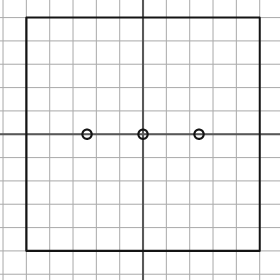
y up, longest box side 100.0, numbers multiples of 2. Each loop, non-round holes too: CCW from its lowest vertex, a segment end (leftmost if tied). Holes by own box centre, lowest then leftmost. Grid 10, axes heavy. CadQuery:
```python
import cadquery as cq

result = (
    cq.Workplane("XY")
    .moveTo(-50.0, -50.0)
    .lineTo(50.0, -50.0)
    .lineTo(50.0, 50.0)
    .lineTo(-50.0, 50.0)
    .close()
    .moveTo(-24.0, 0.0)
    .circle(2.0)
    .moveTo(0.0, 0.0)
    .circle(2.0)
    .moveTo(24.0, 0.0)
    .circle(2.0)
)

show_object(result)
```